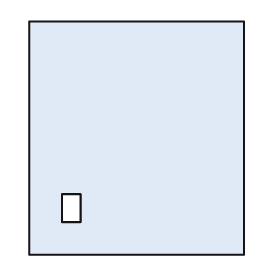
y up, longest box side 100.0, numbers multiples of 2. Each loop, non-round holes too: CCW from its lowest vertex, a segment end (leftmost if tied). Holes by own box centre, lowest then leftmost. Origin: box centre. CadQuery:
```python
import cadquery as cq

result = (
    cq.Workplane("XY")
    .moveTo(-46.0, -50.0)
    .lineTo(46.0, -50.0)
    .lineTo(46.0, 50.0)
    .lineTo(-46.0, 50.0)
    .close()
    .moveTo(-32.0, -36.0)
    .lineTo(-24.0, -36.0)
    .lineTo(-24.0, -24.0)
    .lineTo(-32.0, -24.0)
    .close()
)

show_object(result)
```